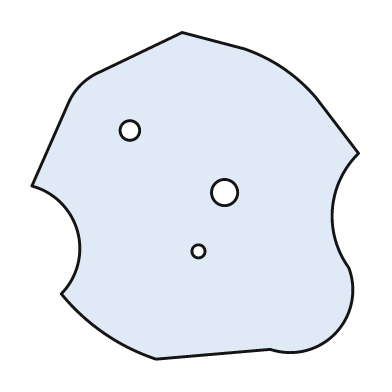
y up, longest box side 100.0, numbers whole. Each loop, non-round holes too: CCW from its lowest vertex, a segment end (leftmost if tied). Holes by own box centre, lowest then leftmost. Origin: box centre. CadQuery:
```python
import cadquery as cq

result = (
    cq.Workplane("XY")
    .moveTo(-12.0, -50.0)
    .lineTo(23.0, -47.0)
    .threePointArc((43.0, -42.0), (47.0, -22.0))
    .threePointArc((42.0, -4.0), (50.0, 13.0))
    .lineTo(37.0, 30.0)
    .threePointArc((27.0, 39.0), (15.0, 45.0))
    .lineTo(-4.0, 50.0)
    .lineTo(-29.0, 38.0)
    .threePointArc((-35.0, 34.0), (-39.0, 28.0))
    .lineTo(-50.0, 3.0)
    .threePointArc((-36.0, -11.0), (-41.0, -30.0))
    .threePointArc((-28.0, -42.0), (-12.0, -50.0))
    .close()
    .moveTo(1.0, -17.0)
    .circle(2.0)
    .moveTo(9.0, 1.0)
    .circle(4.0)
    .moveTo(-20.0, 20.0)
    .circle(3.0)
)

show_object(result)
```